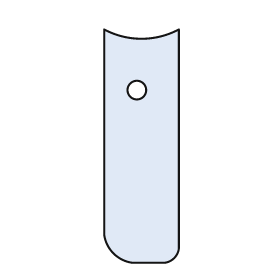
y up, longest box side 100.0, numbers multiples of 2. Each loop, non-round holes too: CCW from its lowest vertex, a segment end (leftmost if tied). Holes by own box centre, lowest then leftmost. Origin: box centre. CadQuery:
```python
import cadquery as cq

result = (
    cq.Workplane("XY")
    .moveTo(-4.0, -50.0)
    .lineTo(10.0, -50.0)
    .threePointArc((14.0, -48.0), (16.0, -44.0))
    .lineTo(16.0, 50.0)
    .threePointArc((0.0, 46.0), (-16.0, 50.0))
    .lineTo(-16.0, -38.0)
    .threePointArc((-12.0, -46.0), (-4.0, -50.0))
    .close()
    .moveTo(-2.0, 24.0)
    .circle(4.0)
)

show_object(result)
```